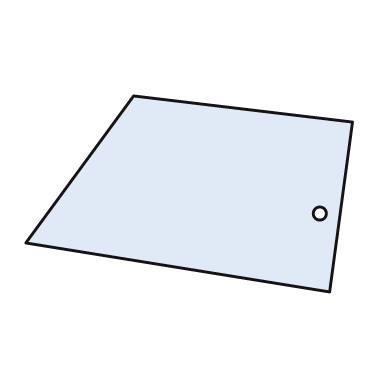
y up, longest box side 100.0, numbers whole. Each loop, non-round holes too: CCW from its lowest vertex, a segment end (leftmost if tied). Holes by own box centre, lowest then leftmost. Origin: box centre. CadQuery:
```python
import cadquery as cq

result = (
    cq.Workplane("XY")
    .moveTo(43.0, -30.0)
    .lineTo(50.0, 22.0)
    .lineTo(-17.0, 30.0)
    .lineTo(-50.0, -15.0)
    .close()
    .moveTo(40.0, -6.0)
    .circle(2.0)
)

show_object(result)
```